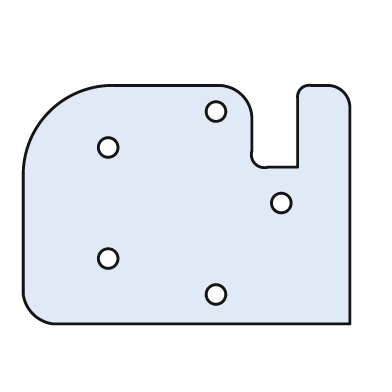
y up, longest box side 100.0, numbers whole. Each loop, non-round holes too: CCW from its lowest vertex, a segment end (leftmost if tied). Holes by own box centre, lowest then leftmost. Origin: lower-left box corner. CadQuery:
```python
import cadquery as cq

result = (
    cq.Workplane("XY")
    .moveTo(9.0, 0.0)
    .lineTo(100.0, 0.0)
    .lineTo(100.0, 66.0)
    .threePointArc((98.0, 71.0), (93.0, 73.0))
    .lineTo(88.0, 73.0)
    .threePointArc((85.0, 72.0), (84.0, 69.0))
    .lineTo(84.0, 48.0)
    .lineTo(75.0, 48.0)
    .threePointArc((71.0, 49.0), (70.0, 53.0))
    .lineTo(70.0, 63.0)
    .threePointArc((67.0, 70.0), (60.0, 73.0))
    .lineTo(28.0, 73.0)
    .threePointArc((8.0, 65.0), (0.0, 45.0))
    .lineTo(0.0, 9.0)
    .threePointArc((3.0, 3.0), (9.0, 0.0))
    .close()
    .moveTo(59.0, 9.0)
    .circle(3.0)
    .moveTo(26.0, 20.0)
    .circle(3.0)
    .moveTo(79.0, 37.0)
    .circle(3.0)
    .moveTo(26.0, 54.0)
    .circle(3.0)
    .moveTo(59.0, 65.0)
    .circle(3.0)
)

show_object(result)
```